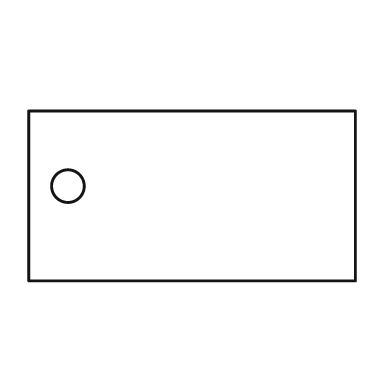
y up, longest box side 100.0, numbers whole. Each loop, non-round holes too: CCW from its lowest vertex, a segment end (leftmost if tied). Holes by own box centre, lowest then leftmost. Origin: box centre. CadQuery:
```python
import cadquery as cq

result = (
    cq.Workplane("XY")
    .moveTo(-50.0, -26.0)
    .lineTo(50.0, -26.0)
    .lineTo(50.0, 26.0)
    .lineTo(-50.0, 26.0)
    .close()
    .moveTo(-38.0, 3.0)
    .circle(5.0)
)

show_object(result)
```